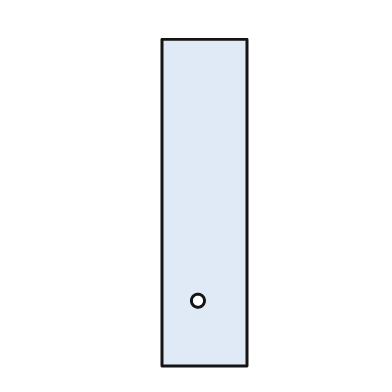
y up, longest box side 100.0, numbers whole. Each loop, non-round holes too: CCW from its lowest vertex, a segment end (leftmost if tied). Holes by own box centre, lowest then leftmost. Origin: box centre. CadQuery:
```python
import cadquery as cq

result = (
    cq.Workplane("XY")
    .moveTo(-13.0, -50.0)
    .lineTo(13.0, -50.0)
    .lineTo(13.0, 50.0)
    .lineTo(-13.0, 50.0)
    .close()
    .moveTo(-2.0, -30.0)
    .circle(2.0)
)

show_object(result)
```